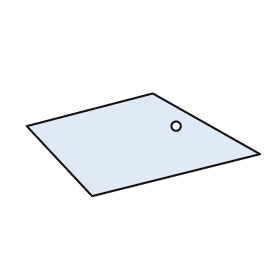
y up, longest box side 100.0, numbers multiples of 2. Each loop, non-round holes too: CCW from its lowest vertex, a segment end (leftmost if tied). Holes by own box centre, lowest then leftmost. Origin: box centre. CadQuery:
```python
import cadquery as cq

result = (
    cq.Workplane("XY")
    .moveTo(-22.0, -22.0)
    .lineTo(50.0, -4.0)
    .lineTo(4.0, 22.0)
    .lineTo(-50.0, 8.0)
    .close()
    .moveTo(14.0, 8.0)
    .circle(2.0)
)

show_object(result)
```